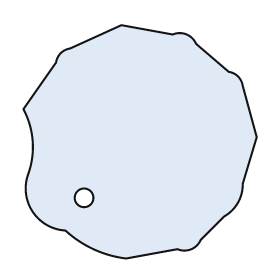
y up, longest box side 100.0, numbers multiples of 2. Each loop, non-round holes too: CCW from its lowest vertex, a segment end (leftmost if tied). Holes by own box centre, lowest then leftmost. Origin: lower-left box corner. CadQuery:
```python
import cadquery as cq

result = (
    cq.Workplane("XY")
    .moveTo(44.0, 0.0)
    .lineTo(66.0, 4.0)
    .threePointArc((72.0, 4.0), (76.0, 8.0))
    .lineTo(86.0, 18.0)
    .threePointArc((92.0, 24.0), (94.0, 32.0))
    .lineTo(100.0, 52.0)
    .lineTo(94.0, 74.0)
    .threePointArc((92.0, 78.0), (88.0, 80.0))
    .lineTo(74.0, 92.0)
    .threePointArc((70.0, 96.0), (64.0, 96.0))
    .lineTo(42.0, 100.0)
    .lineTo(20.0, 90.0)
    .threePointArc((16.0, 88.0), (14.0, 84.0))
    .lineTo(0.0, 64.0)
    .threePointArc((4.0, 50.0), (2.0, 36.0))
    .threePointArc((4.0, 20.0), (18.0, 12.0))
    .threePointArc((30.0, 4.0), (44.0, 0.0))
    .close()
    .moveTo(26.0, 26.0)
    .circle(4.0)
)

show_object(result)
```